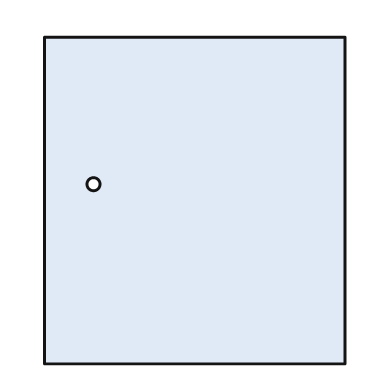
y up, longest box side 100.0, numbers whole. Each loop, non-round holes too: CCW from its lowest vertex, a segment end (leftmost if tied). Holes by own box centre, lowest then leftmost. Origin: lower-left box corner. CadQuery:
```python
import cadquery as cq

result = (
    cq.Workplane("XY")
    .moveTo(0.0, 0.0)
    .lineTo(92.0, 0.0)
    .lineTo(92.0, 100.0)
    .lineTo(0.0, 100.0)
    .close()
    .moveTo(15.0, 55.0)
    .circle(2.0)
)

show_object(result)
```